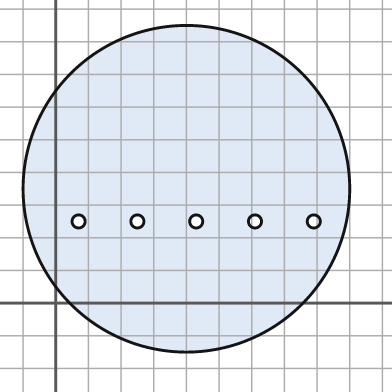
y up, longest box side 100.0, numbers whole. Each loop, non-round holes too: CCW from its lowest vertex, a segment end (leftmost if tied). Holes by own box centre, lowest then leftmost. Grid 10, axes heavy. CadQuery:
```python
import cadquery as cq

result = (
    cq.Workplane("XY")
    .moveTo(40.0, 35.0)
    .circle(50.0)
    .moveTo(7.0, 25.0)
    .circle(2.0)
    .moveTo(25.0, 25.0)
    .circle(2.0)
    .moveTo(43.0, 25.0)
    .circle(2.0)
    .moveTo(61.0, 25.0)
    .circle(2.0)
    .moveTo(79.0, 25.0)
    .circle(2.0)
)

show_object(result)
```